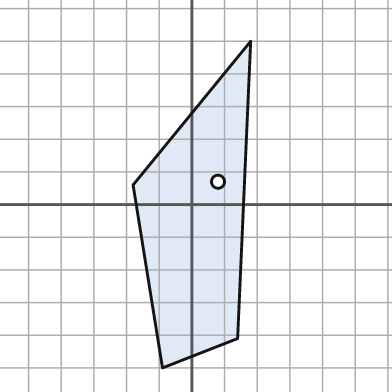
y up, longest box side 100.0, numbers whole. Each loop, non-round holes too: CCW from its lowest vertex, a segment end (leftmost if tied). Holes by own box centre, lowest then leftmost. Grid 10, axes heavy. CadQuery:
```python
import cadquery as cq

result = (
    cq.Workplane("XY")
    .moveTo(-9.0, -50.0)
    .lineTo(14.0, -41.0)
    .lineTo(18.0, 50.0)
    .lineTo(-18.0, 6.0)
    .close()
    .moveTo(8.0, 7.0)
    .circle(2.0)
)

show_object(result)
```